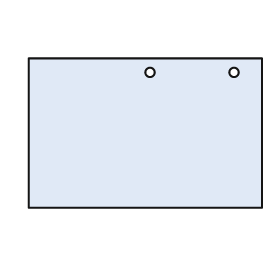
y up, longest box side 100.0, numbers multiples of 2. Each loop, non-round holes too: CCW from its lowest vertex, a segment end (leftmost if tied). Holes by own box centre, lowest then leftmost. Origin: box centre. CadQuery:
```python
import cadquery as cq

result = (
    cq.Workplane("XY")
    .moveTo(-50.0, -32.0)
    .lineTo(50.0, -32.0)
    .lineTo(50.0, 32.0)
    .lineTo(-50.0, 32.0)
    .close()
    .moveTo(2.0, 26.0)
    .circle(2.0)
    .moveTo(38.0, 26.0)
    .circle(2.0)
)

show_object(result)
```